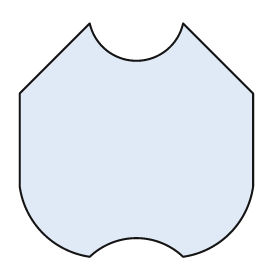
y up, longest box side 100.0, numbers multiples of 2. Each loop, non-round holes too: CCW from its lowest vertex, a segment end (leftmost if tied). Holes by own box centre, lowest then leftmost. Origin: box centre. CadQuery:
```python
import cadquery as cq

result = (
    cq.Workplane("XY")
    .moveTo(-20.0, -50.0)
    .threePointArc((0.0, -42.0), (20.0, -50.0))
    .threePointArc((40.0, -40.0), (50.0, -20.0))
    .lineTo(50.0, 20.0)
    .lineTo(20.0, 50.0)
    .threePointArc((0.0, 34.0), (-20.0, 50.0))
    .lineTo(-50.0, 20.0)
    .lineTo(-50.0, -20.0)
    .threePointArc((-40.0, -40.0), (-20.0, -50.0))
    .close()
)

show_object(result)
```